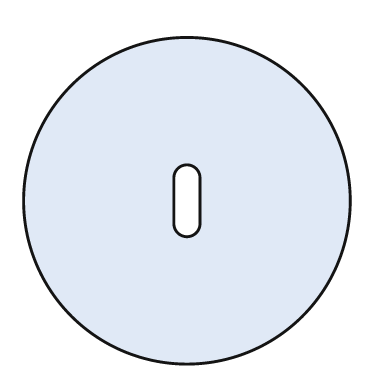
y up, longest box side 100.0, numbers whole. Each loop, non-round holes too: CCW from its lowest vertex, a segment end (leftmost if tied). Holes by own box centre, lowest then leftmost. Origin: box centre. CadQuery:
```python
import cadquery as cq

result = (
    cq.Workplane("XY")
    .moveTo(0.0, 0.0)
    .circle(50.0)
    .moveTo(-4.0, -7.0)
    .threePointArc((0.0, -11.0), (4.0, -7.0))
    .lineTo(4.0, 7.0)
    .threePointArc((0.0, 11.0), (-4.0, 7.0))
    .close()
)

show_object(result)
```